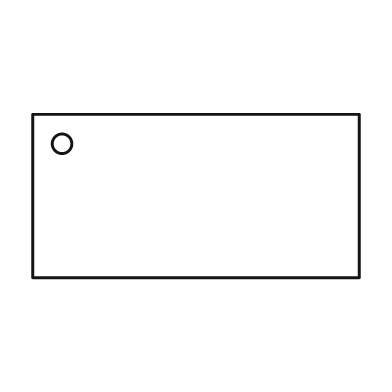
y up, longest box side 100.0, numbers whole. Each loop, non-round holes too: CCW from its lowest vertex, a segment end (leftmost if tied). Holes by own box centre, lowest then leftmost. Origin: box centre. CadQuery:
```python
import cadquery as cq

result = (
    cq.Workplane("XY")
    .moveTo(-50.0, -25.0)
    .lineTo(50.0, -25.0)
    .lineTo(50.0, 25.0)
    .lineTo(-50.0, 25.0)
    .close()
    .moveTo(-41.0, 16.0)
    .circle(3.0)
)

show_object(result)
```